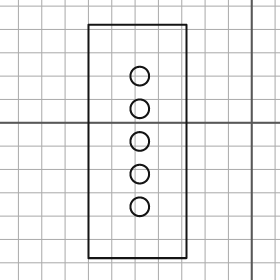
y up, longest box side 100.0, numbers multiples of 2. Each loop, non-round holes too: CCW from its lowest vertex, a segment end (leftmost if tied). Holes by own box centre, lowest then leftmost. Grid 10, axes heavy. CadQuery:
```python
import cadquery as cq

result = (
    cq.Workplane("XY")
    .moveTo(-70.0, -58.0)
    .lineTo(-28.0, -58.0)
    .lineTo(-28.0, 42.0)
    .lineTo(-70.0, 42.0)
    .close()
    .moveTo(-48.0, -36.0)
    .circle(4.0)
    .moveTo(-48.0, -22.0)
    .circle(4.0)
    .moveTo(-48.0, -8.0)
    .circle(4.0)
    .moveTo(-48.0, 6.0)
    .circle(4.0)
    .moveTo(-48.0, 20.0)
    .circle(4.0)
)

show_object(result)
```